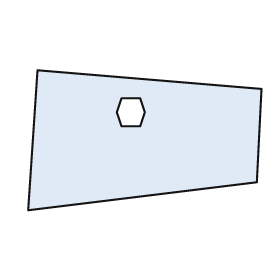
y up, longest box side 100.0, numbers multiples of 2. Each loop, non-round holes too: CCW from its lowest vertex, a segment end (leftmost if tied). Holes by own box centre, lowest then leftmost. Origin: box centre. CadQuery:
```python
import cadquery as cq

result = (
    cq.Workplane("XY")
    .moveTo(-50.0, -30.0)
    .lineTo(48.0, -18.0)
    .lineTo(50.0, 22.0)
    .lineTo(-46.0, 30.0)
    .close()
    .moveTo(-10.0, 6.0)
    .lineTo(-2.0, 6.0)
    .lineTo(0.0, 12.0)
    .lineTo(-2.0, 18.0)
    .lineTo(-10.0, 18.0)
    .lineTo(-12.0, 12.0)
    .close()
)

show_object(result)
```